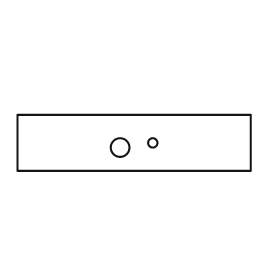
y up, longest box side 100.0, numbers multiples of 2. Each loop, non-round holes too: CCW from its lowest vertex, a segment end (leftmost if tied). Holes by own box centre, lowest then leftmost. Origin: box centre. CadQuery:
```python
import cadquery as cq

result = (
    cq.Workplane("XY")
    .moveTo(-50.0, -12.0)
    .lineTo(50.0, -12.0)
    .lineTo(50.0, 12.0)
    .lineTo(-50.0, 12.0)
    .close()
    .moveTo(-6.0, -2.0)
    .circle(4.0)
    .moveTo(8.0, 0.0)
    .circle(2.0)
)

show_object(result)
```